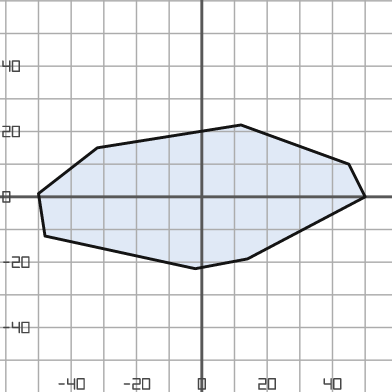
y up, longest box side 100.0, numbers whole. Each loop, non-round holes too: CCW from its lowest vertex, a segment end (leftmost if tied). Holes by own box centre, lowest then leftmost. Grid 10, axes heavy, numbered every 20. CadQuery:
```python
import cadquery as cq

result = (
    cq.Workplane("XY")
    .moveTo(-2.0, -22.0)
    .lineTo(14.0, -19.0)
    .lineTo(50.0, 0.0)
    .lineTo(45.0, 10.0)
    .lineTo(12.0, 22.0)
    .lineTo(-32.0, 15.0)
    .lineTo(-50.0, 1.0)
    .lineTo(-48.0, -12.0)
    .close()
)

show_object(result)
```